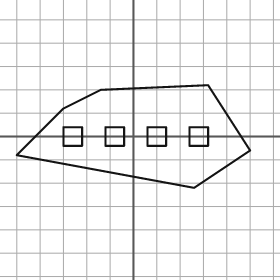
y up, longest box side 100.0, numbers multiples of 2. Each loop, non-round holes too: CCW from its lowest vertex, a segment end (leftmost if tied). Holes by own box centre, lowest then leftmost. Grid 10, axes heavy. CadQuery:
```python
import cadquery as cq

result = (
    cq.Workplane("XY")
    .moveTo(26.0, -22.0)
    .lineTo(50.0, -6.0)
    .lineTo(32.0, 22.0)
    .lineTo(-14.0, 20.0)
    .lineTo(-30.0, 12.0)
    .lineTo(-50.0, -8.0)
    .close()
    .moveTo(-30.0, -4.0)
    .lineTo(-22.0, -4.0)
    .lineTo(-22.0, 4.0)
    .lineTo(-30.0, 4.0)
    .close()
    .moveTo(-12.0, -4.0)
    .lineTo(-4.0, -4.0)
    .lineTo(-4.0, 4.0)
    .lineTo(-12.0, 4.0)
    .close()
    .moveTo(6.0, -4.0)
    .lineTo(14.0, -4.0)
    .lineTo(14.0, 4.0)
    .lineTo(6.0, 4.0)
    .close()
    .moveTo(24.0, -4.0)
    .lineTo(32.0, -4.0)
    .lineTo(32.0, 4.0)
    .lineTo(24.0, 4.0)
    .close()
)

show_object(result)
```